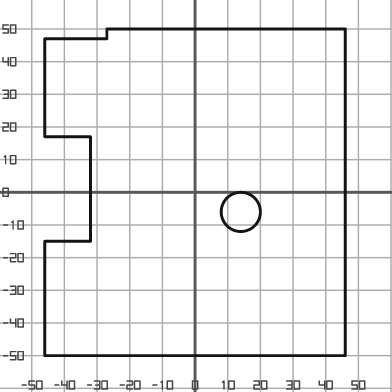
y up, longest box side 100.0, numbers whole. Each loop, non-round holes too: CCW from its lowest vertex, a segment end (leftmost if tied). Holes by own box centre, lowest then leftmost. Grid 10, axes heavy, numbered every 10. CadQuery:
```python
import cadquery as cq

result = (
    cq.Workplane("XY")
    .moveTo(-46.0, -50.0)
    .lineTo(46.0, -50.0)
    .lineTo(46.0, 50.0)
    .lineTo(-27.0, 50.0)
    .lineTo(-27.0, 47.0)
    .lineTo(-46.0, 47.0)
    .lineTo(-46.0, 17.0)
    .lineTo(-32.0, 17.0)
    .lineTo(-32.0, -15.0)
    .lineTo(-46.0, -15.0)
    .close()
    .moveTo(14.0, -6.0)
    .circle(6.0)
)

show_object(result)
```